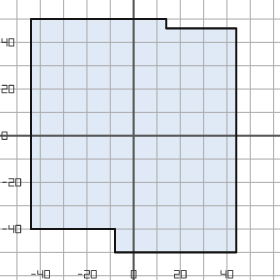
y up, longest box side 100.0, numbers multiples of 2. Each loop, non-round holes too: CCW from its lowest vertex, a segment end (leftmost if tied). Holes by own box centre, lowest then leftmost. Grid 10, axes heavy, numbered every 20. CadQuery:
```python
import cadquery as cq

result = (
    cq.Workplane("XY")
    .moveTo(-8.0, -50.0)
    .lineTo(44.0, -50.0)
    .lineTo(44.0, 46.0)
    .lineTo(14.0, 46.0)
    .lineTo(14.0, 50.0)
    .lineTo(-44.0, 50.0)
    .lineTo(-44.0, -40.0)
    .lineTo(-8.0, -40.0)
    .close()
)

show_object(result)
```